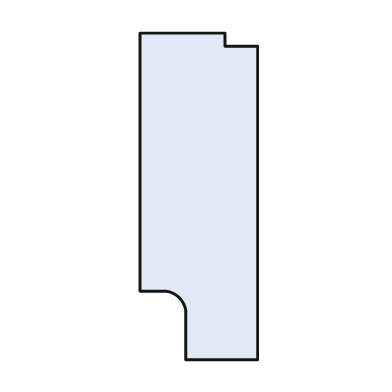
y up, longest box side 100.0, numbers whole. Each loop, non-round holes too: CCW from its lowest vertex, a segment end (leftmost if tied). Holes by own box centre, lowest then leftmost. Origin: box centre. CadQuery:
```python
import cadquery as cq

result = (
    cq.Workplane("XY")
    .moveTo(-4.0, -50.0)
    .lineTo(18.0, -50.0)
    .lineTo(18.0, 46.0)
    .lineTo(8.0, 46.0)
    .lineTo(8.0, 50.0)
    .lineTo(-18.0, 50.0)
    .lineTo(-18.0, -29.0)
    .lineTo(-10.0, -29.0)
    .threePointArc((-6.0, -31.0), (-4.0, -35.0))
    .close()
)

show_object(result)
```